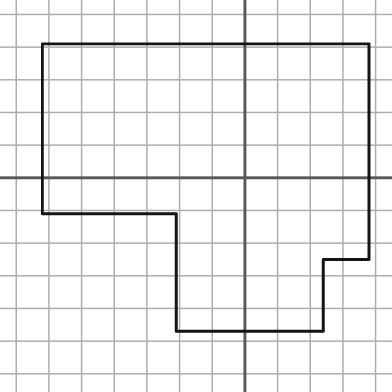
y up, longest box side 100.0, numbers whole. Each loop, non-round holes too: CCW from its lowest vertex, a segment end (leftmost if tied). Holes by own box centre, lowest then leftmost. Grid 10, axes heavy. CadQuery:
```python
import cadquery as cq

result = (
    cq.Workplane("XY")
    .moveTo(-21.0, -47.0)
    .lineTo(24.0, -47.0)
    .lineTo(24.0, -25.0)
    .lineTo(38.0, -25.0)
    .lineTo(38.0, 41.0)
    .lineTo(-62.0, 41.0)
    .lineTo(-62.0, -11.0)
    .lineTo(-21.0, -11.0)
    .close()
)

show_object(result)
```